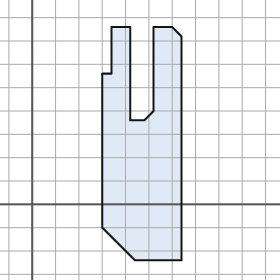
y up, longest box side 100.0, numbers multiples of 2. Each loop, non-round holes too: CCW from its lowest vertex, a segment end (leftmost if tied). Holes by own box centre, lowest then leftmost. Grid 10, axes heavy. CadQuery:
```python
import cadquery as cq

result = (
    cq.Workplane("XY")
    .moveTo(44.0, -24.0)
    .lineTo(64.0, -24.0)
    .lineTo(64.0, 72.0)
    .lineTo(60.0, 76.0)
    .lineTo(52.0, 76.0)
    .lineTo(52.0, 40.0)
    .lineTo(48.0, 36.0)
    .lineTo(42.0, 36.0)
    .lineTo(42.0, 76.0)
    .lineTo(34.0, 76.0)
    .lineTo(34.0, 56.0)
    .lineTo(30.0, 56.0)
    .lineTo(30.0, -10.0)
    .close()
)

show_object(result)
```